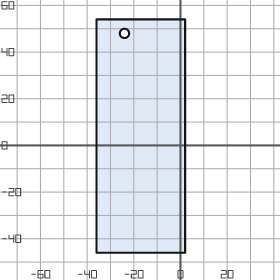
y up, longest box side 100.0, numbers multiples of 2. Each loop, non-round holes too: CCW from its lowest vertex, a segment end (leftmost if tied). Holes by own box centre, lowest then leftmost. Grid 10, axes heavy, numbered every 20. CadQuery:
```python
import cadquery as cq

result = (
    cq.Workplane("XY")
    .moveTo(-36.0, -46.0)
    .lineTo(2.0, -46.0)
    .lineTo(2.0, 54.0)
    .lineTo(-36.0, 54.0)
    .close()
    .moveTo(-24.0, 48.0)
    .circle(2.0)
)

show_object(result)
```